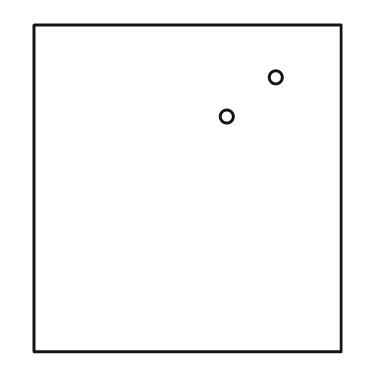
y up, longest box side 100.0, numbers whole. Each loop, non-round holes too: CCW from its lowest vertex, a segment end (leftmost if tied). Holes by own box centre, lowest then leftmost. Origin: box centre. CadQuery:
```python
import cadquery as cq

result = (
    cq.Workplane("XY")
    .moveTo(-47.0, -50.0)
    .lineTo(47.0, -50.0)
    .lineTo(47.0, 50.0)
    .lineTo(-47.0, 50.0)
    .close()
    .moveTo(12.0, 22.0)
    .circle(2.0)
    .moveTo(27.0, 34.0)
    .circle(2.0)
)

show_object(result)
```